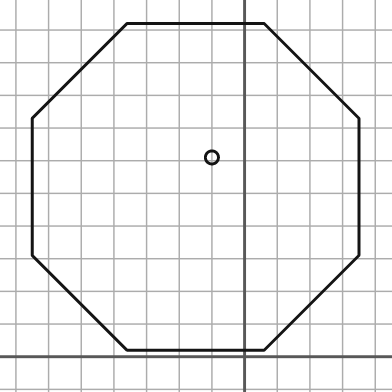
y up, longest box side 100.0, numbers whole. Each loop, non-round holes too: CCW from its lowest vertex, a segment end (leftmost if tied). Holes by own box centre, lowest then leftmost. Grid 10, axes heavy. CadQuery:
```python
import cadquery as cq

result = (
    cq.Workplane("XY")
    .moveTo(-36.0, 2.0)
    .lineTo(6.0, 2.0)
    .lineTo(35.0, 31.0)
    .lineTo(35.0, 73.0)
    .lineTo(6.0, 102.0)
    .lineTo(-36.0, 102.0)
    .lineTo(-65.0, 73.0)
    .lineTo(-65.0, 31.0)
    .close()
    .moveTo(-10.0, 61.0)
    .circle(2.0)
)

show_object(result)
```